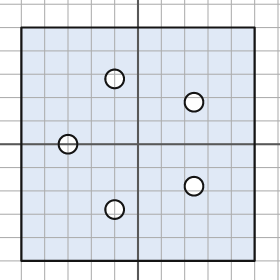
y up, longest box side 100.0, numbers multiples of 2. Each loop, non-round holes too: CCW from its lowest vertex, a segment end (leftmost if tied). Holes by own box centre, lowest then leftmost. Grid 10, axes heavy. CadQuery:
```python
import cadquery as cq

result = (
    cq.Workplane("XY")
    .moveTo(-50.0, -50.0)
    .lineTo(50.0, -50.0)
    .lineTo(50.0, 50.0)
    .lineTo(-50.0, 50.0)
    .close()
    .moveTo(-10.0, -28.0)
    .circle(4.0)
    .moveTo(24.0, -18.0)
    .circle(4.0)
    .moveTo(-30.0, 0.0)
    .circle(4.0)
    .moveTo(24.0, 18.0)
    .circle(4.0)
    .moveTo(-10.0, 28.0)
    .circle(4.0)
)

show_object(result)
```